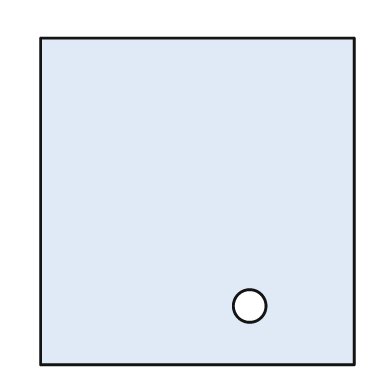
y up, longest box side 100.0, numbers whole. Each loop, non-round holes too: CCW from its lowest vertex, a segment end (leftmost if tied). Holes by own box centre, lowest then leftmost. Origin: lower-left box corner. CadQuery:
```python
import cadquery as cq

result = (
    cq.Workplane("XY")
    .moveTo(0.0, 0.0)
    .lineTo(96.0, 0.0)
    .lineTo(96.0, 100.0)
    .lineTo(0.0, 100.0)
    .close()
    .moveTo(64.0, 18.0)
    .circle(5.0)
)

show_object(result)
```